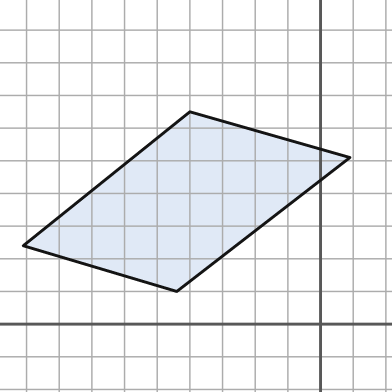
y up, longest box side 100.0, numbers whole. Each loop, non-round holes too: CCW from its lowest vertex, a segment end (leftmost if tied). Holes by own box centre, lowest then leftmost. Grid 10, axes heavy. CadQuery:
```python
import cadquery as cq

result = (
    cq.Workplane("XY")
    .moveTo(-44.0, 10.0)
    .lineTo(9.0, 51.0)
    .lineTo(-40.0, 65.0)
    .lineTo(-91.0, 24.0)
    .close()
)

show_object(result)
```